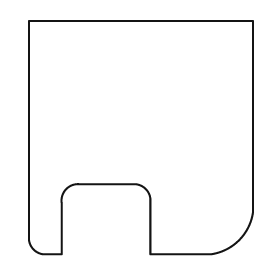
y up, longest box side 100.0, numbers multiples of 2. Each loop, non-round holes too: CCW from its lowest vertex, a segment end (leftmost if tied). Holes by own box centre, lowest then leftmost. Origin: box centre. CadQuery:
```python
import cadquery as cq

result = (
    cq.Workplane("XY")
    .moveTo(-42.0, -50.0)
    .lineTo(-34.0, -50.0)
    .lineTo(-34.0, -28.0)
    .threePointArc((-32.0, -22.0), (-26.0, -20.0))
    .lineTo(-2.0, -20.0)
    .threePointArc((2.0, -22.0), (4.0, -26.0))
    .lineTo(4.0, -50.0)
    .lineTo(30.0, -50.0)
    .threePointArc((42.0, -44.0), (48.0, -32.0))
    .lineTo(48.0, 50.0)
    .lineTo(-48.0, 50.0)
    .lineTo(-48.0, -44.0)
    .threePointArc((-46.0, -48.0), (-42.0, -50.0))
    .close()
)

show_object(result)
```